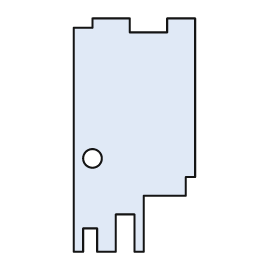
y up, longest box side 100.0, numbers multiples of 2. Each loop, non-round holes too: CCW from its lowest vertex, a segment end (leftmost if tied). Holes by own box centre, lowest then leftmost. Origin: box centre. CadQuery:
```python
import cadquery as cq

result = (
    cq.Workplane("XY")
    .moveTo(-26.0, -50.0)
    .lineTo(-22.0, -50.0)
    .lineTo(-22.0, -40.0)
    .lineTo(-16.0, -40.0)
    .lineTo(-16.0, -50.0)
    .lineTo(-8.0, -50.0)
    .lineTo(-8.0, -34.0)
    .lineTo(0.0, -34.0)
    .lineTo(0.0, -50.0)
    .lineTo(4.0, -50.0)
    .lineTo(4.0, -26.0)
    .lineTo(22.0, -26.0)
    .lineTo(22.0, -18.0)
    .lineTo(26.0, -18.0)
    .lineTo(26.0, 50.0)
    .lineTo(14.0, 50.0)
    .lineTo(14.0, 44.0)
    .lineTo(-2.0, 44.0)
    .lineTo(-2.0, 50.0)
    .lineTo(-18.0, 50.0)
    .lineTo(-18.0, 46.0)
    .lineTo(-26.0, 46.0)
    .close()
    .moveTo(-18.0, -10.0)
    .circle(4.0)
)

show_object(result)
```